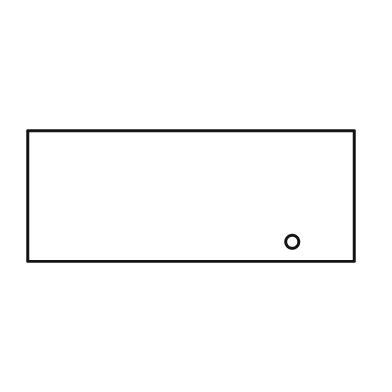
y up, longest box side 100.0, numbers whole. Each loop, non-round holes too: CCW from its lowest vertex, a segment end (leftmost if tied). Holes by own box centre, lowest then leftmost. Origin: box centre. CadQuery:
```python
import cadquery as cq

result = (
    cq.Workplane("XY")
    .moveTo(-50.0, -20.0)
    .lineTo(50.0, -20.0)
    .lineTo(50.0, 20.0)
    .lineTo(-50.0, 20.0)
    .close()
    .moveTo(31.0, -14.0)
    .circle(2.0)
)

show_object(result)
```